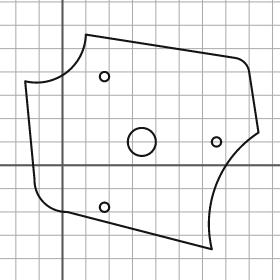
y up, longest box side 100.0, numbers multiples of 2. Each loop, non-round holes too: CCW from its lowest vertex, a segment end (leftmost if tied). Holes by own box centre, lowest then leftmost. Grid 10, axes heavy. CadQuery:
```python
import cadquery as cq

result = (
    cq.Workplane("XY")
    .moveTo(64.0, -36.0)
    .threePointArc((66.0, -8.0), (84.0, 14.0))
    .lineTo(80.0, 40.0)
    .threePointArc((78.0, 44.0), (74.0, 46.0))
    .lineTo(10.0, 56.0)
    .threePointArc((2.0, 40.0), (-16.0, 36.0))
    .lineTo(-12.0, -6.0)
    .threePointArc((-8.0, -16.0), (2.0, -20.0))
    .close()
    .moveTo(18.0, -18.0)
    .circle(2.0)
    .moveTo(34.0, 10.0)
    .circle(6.0)
    .moveTo(66.0, 10.0)
    .circle(2.0)
    .moveTo(18.0, 38.0)
    .circle(2.0)
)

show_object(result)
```